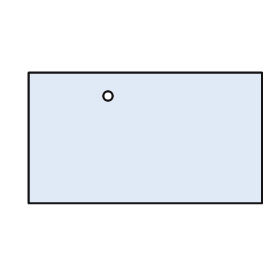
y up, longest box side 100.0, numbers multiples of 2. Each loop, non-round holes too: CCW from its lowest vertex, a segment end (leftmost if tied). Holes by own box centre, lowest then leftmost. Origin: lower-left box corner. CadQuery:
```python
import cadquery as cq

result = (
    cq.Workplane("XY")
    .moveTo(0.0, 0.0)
    .lineTo(100.0, 0.0)
    .lineTo(100.0, 56.0)
    .lineTo(0.0, 56.0)
    .close()
    .moveTo(34.0, 46.0)
    .circle(2.0)
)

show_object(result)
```